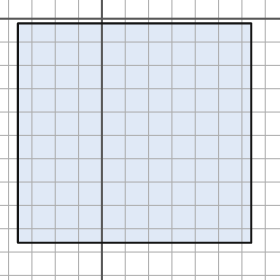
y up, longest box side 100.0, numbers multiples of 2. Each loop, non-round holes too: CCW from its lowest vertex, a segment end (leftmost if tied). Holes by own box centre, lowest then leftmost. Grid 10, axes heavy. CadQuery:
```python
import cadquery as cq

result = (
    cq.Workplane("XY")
    .moveTo(-36.0, -96.0)
    .lineTo(64.0, -96.0)
    .lineTo(64.0, -2.0)
    .lineTo(-36.0, -2.0)
    .close()
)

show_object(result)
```